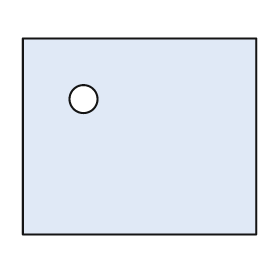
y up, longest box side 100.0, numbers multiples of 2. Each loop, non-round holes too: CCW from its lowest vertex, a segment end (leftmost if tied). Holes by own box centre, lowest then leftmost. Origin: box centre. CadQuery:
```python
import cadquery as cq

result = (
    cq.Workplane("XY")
    .moveTo(-50.0, -42.0)
    .lineTo(50.0, -42.0)
    .lineTo(50.0, 42.0)
    .lineTo(-50.0, 42.0)
    .close()
    .moveTo(-24.0, 16.0)
    .circle(6.0)
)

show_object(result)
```